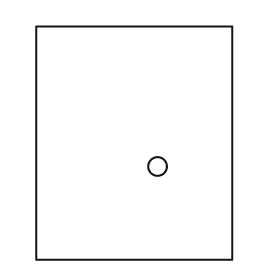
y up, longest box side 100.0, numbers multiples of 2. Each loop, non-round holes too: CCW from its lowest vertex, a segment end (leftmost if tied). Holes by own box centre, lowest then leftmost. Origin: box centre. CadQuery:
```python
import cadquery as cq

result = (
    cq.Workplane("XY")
    .moveTo(-42.0, -50.0)
    .lineTo(42.0, -50.0)
    .lineTo(42.0, 50.0)
    .lineTo(-42.0, 50.0)
    .close()
    .moveTo(10.0, -10.0)
    .circle(4.0)
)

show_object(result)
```